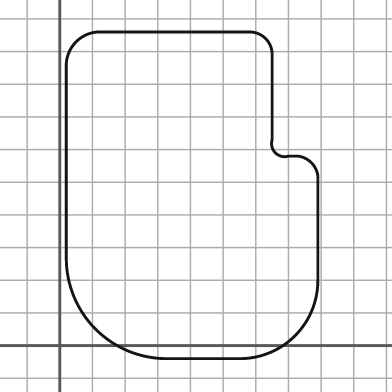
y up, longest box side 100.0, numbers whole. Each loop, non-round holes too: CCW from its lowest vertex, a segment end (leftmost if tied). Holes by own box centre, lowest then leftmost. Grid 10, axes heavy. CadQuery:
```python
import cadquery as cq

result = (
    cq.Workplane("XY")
    .moveTo(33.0, -4.0)
    .lineTo(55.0, -4.0)
    .threePointArc((72.0, 3.0), (79.0, 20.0))
    .lineTo(79.0, 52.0)
    .threePointArc((77.0, 56.0), (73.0, 58.0))
    .lineTo(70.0, 58.0)
    .threePointArc((66.0, 59.0), (65.0, 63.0))
    .lineTo(65.0, 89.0)
    .threePointArc((63.0, 94.0), (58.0, 96.0))
    .lineTo(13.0, 96.0)
    .threePointArc((5.0, 93.0), (2.0, 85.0))
    .lineTo(2.0, 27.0)
    .threePointArc((11.0, 5.0), (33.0, -4.0))
    .close()
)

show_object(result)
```